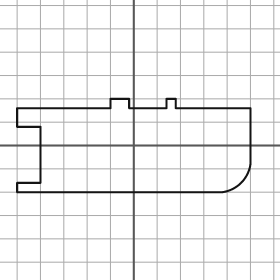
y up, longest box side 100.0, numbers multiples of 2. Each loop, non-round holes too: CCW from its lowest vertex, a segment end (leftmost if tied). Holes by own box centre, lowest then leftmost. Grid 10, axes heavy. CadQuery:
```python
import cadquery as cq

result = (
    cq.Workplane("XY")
    .moveTo(-50.0, -20.0)
    .lineTo(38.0, -20.0)
    .threePointArc((46.0, -16.0), (50.0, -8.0))
    .lineTo(50.0, 16.0)
    .lineTo(18.0, 16.0)
    .lineTo(18.0, 20.0)
    .lineTo(14.0, 20.0)
    .lineTo(14.0, 16.0)
    .lineTo(-2.0, 16.0)
    .lineTo(-2.0, 20.0)
    .lineTo(-10.0, 20.0)
    .lineTo(-10.0, 16.0)
    .lineTo(-50.0, 16.0)
    .lineTo(-50.0, 8.0)
    .lineTo(-40.0, 8.0)
    .lineTo(-40.0, -16.0)
    .lineTo(-50.0, -16.0)
    .close()
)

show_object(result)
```